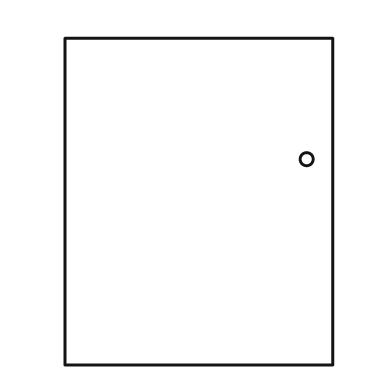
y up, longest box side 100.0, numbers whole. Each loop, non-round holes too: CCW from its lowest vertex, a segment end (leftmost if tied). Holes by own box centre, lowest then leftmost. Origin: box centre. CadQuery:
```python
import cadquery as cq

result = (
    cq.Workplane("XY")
    .moveTo(-41.0, -50.0)
    .lineTo(41.0, -50.0)
    .lineTo(41.0, 50.0)
    .lineTo(-41.0, 50.0)
    .close()
    .moveTo(33.0, 13.0)
    .circle(2.0)
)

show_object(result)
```